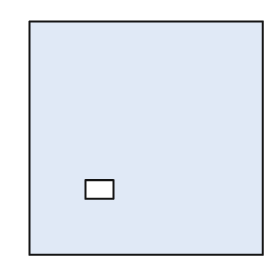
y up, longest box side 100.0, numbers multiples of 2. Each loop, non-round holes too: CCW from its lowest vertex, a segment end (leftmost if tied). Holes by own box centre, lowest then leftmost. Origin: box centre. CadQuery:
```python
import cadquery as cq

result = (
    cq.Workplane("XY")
    .moveTo(-50.0, -50.0)
    .lineTo(50.0, -50.0)
    .lineTo(50.0, 50.0)
    .lineTo(-50.0, 50.0)
    .close()
    .moveTo(-26.0, -26.0)
    .lineTo(-14.0, -26.0)
    .lineTo(-14.0, -18.0)
    .lineTo(-26.0, -18.0)
    .close()
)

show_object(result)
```